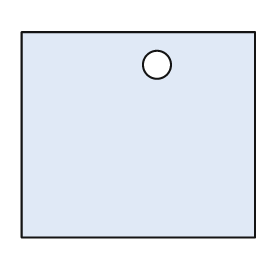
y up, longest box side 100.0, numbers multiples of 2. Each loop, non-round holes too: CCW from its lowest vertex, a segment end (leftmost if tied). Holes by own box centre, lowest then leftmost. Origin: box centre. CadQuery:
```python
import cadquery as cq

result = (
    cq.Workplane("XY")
    .moveTo(-50.0, -44.0)
    .lineTo(50.0, -44.0)
    .lineTo(50.0, 44.0)
    .lineTo(-50.0, 44.0)
    .close()
    .moveTo(8.0, 30.0)
    .circle(6.0)
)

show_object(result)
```